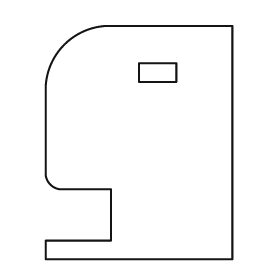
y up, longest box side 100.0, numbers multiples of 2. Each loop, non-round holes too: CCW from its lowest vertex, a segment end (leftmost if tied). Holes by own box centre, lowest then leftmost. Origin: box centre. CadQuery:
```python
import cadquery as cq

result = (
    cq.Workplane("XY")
    .moveTo(-40.0, -50.0)
    .lineTo(40.0, -50.0)
    .lineTo(40.0, 50.0)
    .lineTo(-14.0, 50.0)
    .threePointArc((-32.0, 42.0), (-40.0, 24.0))
    .lineTo(-40.0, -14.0)
    .threePointArc((-38.0, -18.0), (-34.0, -20.0))
    .lineTo(-12.0, -20.0)
    .lineTo(-12.0, -42.0)
    .lineTo(-40.0, -42.0)
    .close()
    .moveTo(0.0, 26.0)
    .lineTo(16.0, 26.0)
    .lineTo(16.0, 34.0)
    .lineTo(0.0, 34.0)
    .close()
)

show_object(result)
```